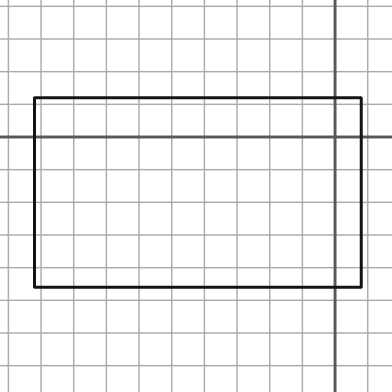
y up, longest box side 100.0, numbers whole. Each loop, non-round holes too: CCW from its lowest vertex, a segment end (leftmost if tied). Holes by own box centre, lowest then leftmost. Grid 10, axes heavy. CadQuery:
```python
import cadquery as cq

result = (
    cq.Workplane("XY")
    .moveTo(-92.0, -46.0)
    .lineTo(8.0, -46.0)
    .lineTo(8.0, 12.0)
    .lineTo(-92.0, 12.0)
    .close()
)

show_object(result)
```